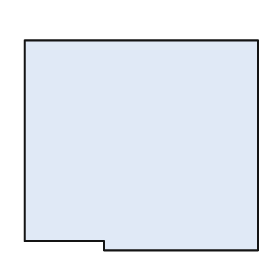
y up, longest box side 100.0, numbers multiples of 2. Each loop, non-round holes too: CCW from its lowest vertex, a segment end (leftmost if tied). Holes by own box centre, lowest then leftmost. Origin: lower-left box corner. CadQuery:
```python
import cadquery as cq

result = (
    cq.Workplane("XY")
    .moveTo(34.0, 0.0)
    .lineTo(100.0, 0.0)
    .lineTo(100.0, 90.0)
    .lineTo(0.0, 90.0)
    .lineTo(0.0, 4.0)
    .lineTo(34.0, 4.0)
    .close()
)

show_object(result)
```